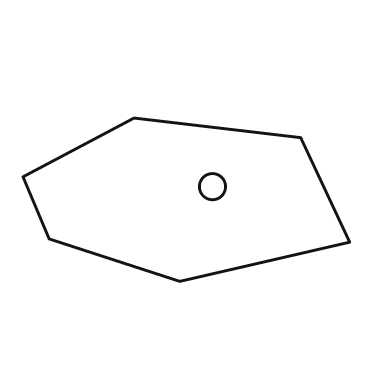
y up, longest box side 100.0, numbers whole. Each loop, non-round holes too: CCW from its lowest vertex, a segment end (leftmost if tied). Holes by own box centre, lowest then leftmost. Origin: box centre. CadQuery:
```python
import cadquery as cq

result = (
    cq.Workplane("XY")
    .moveTo(-2.0, -25.0)
    .lineTo(50.0, -13.0)
    .lineTo(35.0, 19.0)
    .lineTo(-16.0, 25.0)
    .lineTo(-50.0, 7.0)
    .lineTo(-42.0, -12.0)
    .close()
    .moveTo(8.0, 4.0)
    .circle(4.0)
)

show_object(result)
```